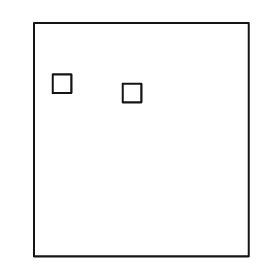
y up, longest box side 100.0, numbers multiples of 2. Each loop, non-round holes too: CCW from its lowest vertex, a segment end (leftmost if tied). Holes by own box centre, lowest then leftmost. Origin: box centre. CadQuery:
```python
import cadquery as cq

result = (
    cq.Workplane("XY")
    .moveTo(-46.0, -50.0)
    .lineTo(46.0, -50.0)
    .lineTo(46.0, 50.0)
    .lineTo(-46.0, 50.0)
    .close()
    .moveTo(-8.0, 16.0)
    .lineTo(0.0, 16.0)
    .lineTo(0.0, 24.0)
    .lineTo(-8.0, 24.0)
    .close()
    .moveTo(-38.0, 20.0)
    .lineTo(-30.0, 20.0)
    .lineTo(-30.0, 28.0)
    .lineTo(-38.0, 28.0)
    .close()
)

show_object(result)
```